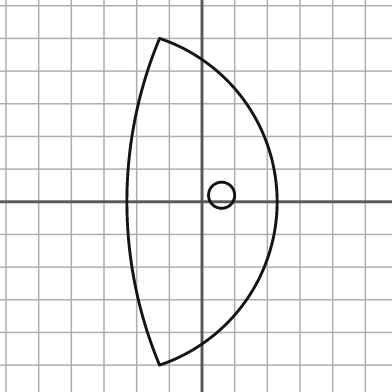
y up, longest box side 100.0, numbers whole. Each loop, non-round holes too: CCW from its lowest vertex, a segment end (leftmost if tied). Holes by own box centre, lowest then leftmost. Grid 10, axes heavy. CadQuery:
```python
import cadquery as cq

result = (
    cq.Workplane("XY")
    .moveTo(-13.0, -50.0)
    .threePointArc((23.0, 0.0), (-13.0, 50.0))
    .threePointArc((-23.0, 0.0), (-13.0, -50.0))
    .close()
    .moveTo(6.0, 2.0)
    .circle(4.0)
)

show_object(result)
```